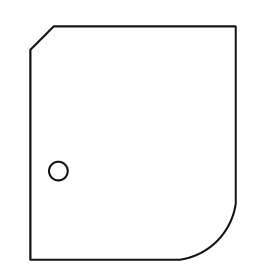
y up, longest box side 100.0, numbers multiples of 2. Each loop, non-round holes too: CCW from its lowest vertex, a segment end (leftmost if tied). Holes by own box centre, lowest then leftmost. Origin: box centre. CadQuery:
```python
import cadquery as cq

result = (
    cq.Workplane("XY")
    .moveTo(-44.0, -50.0)
    .lineTo(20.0, -50.0)
    .threePointArc((36.0, -42.0), (44.0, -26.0))
    .lineTo(44.0, 50.0)
    .lineTo(-34.0, 50.0)
    .lineTo(-44.0, 40.0)
    .close()
    .moveTo(-32.0, -12.0)
    .circle(4.0)
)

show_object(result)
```